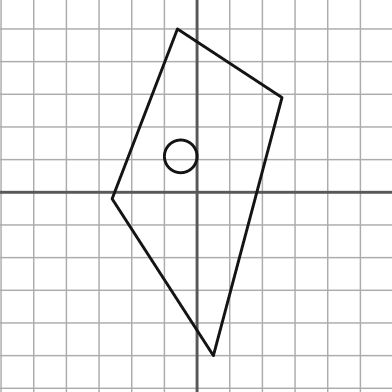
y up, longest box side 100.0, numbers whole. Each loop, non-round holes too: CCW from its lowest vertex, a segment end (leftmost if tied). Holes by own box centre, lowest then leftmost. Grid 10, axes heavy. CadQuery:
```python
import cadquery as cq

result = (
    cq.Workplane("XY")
    .moveTo(5.0, -50.0)
    .lineTo(26.0, 29.0)
    .lineTo(-6.0, 50.0)
    .lineTo(-26.0, -2.0)
    .close()
    .moveTo(-5.0, 11.0)
    .circle(5.0)
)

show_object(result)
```